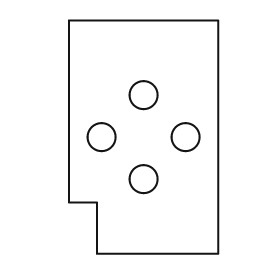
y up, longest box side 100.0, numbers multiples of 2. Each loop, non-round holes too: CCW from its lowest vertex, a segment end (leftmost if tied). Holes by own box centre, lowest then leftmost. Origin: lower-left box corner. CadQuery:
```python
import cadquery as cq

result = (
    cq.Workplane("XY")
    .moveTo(12.0, 0.0)
    .lineTo(64.0, 0.0)
    .lineTo(64.0, 100.0)
    .lineTo(0.0, 100.0)
    .lineTo(0.0, 22.0)
    .lineTo(12.0, 22.0)
    .close()
    .moveTo(32.0, 32.0)
    .circle(6.0)
    .moveTo(14.0, 50.0)
    .circle(6.0)
    .moveTo(50.0, 50.0)
    .circle(6.0)
    .moveTo(32.0, 68.0)
    .circle(6.0)
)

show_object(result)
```